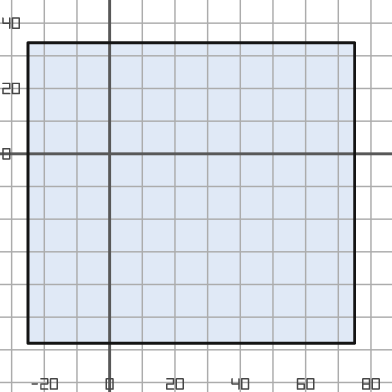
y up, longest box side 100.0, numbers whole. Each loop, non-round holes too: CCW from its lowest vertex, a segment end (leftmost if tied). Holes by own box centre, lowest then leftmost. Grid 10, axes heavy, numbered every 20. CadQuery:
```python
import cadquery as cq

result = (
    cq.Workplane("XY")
    .moveTo(-25.0, -58.0)
    .lineTo(75.0, -58.0)
    .lineTo(75.0, 34.0)
    .lineTo(-25.0, 34.0)
    .close()
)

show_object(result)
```